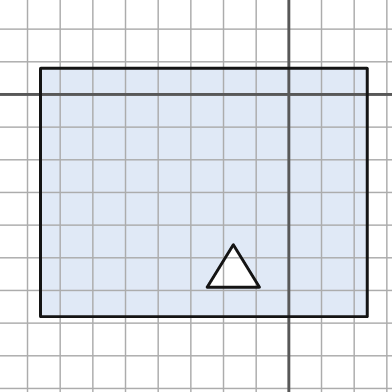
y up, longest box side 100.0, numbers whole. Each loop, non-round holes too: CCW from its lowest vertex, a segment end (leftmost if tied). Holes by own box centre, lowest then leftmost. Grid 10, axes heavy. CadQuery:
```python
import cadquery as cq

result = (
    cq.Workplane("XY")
    .moveTo(-76.0, -68.0)
    .lineTo(24.0, -68.0)
    .lineTo(24.0, 8.0)
    .lineTo(-76.0, 8.0)
    .close()
    .moveTo(-25.0, -59.0)
    .lineTo(-9.0, -59.0)
    .lineTo(-17.0, -46.0)
    .close()
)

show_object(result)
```